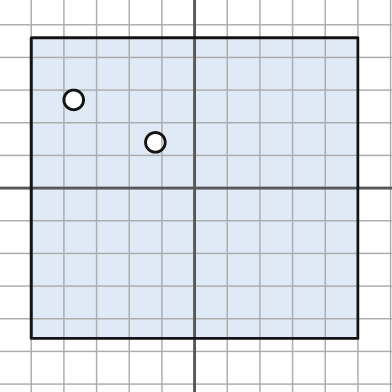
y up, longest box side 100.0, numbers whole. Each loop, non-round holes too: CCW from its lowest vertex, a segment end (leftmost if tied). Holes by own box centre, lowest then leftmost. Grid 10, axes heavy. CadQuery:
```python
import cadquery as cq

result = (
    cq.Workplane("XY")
    .moveTo(-50.0, -46.0)
    .lineTo(50.0, -46.0)
    .lineTo(50.0, 46.0)
    .lineTo(-50.0, 46.0)
    .close()
    .moveTo(-12.0, 14.0)
    .circle(3.0)
    .moveTo(-37.0, 27.0)
    .circle(3.0)
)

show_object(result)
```